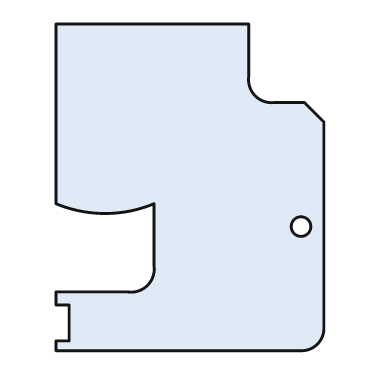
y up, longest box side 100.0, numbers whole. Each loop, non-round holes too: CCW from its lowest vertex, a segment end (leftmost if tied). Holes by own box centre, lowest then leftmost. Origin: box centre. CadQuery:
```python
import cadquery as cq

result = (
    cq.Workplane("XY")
    .moveTo(-41.0, -50.0)
    .lineTo(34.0, -50.0)
    .threePointArc((39.0, -48.0), (41.0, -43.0))
    .lineTo(41.0, 20.0)
    .lineTo(35.0, 26.0)
    .lineTo(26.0, 26.0)
    .threePointArc((20.0, 28.0), (18.0, 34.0))
    .lineTo(18.0, 50.0)
    .lineTo(-41.0, 50.0)
    .lineTo(-41.0, -5.0)
    .threePointArc((-26.0, -8.0), (-11.0, -5.0))
    .lineTo(-11.0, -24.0)
    .threePointArc((-13.0, -30.0), (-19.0, -32.0))
    .lineTo(-41.0, -32.0)
    .lineTo(-41.0, -36.0)
    .lineTo(-37.0, -36.0)
    .lineTo(-37.0, -47.0)
    .lineTo(-41.0, -47.0)
    .close()
    .moveTo(34.0, -12.0)
    .circle(3.0)
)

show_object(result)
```